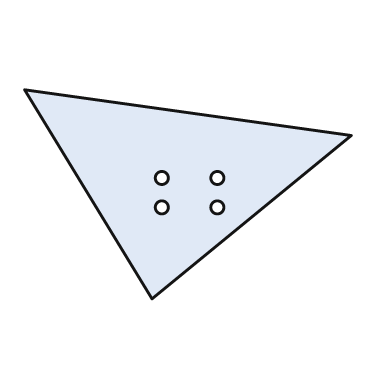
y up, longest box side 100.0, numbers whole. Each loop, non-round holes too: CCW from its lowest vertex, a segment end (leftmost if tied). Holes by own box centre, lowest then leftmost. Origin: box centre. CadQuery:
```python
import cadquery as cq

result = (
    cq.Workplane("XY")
    .moveTo(-11.0, -32.0)
    .lineTo(50.0, 18.0)
    .lineTo(-50.0, 32.0)
    .close()
    .moveTo(-8.0, -4.0)
    .circle(2.0)
    .moveTo(9.0, -4.0)
    .circle(2.0)
    .moveTo(-8.0, 5.0)
    .circle(2.0)
    .moveTo(9.0, 5.0)
    .circle(2.0)
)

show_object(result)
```